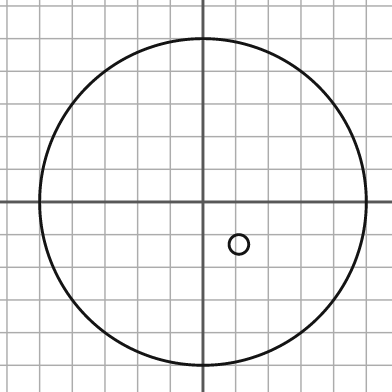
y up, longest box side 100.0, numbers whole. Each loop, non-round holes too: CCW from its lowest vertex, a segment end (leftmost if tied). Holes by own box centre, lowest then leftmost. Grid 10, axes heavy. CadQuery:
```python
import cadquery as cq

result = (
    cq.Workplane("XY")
    .moveTo(0.0, 0.0)
    .circle(50.0)
    .moveTo(11.0, -13.0)
    .circle(3.0)
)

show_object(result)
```